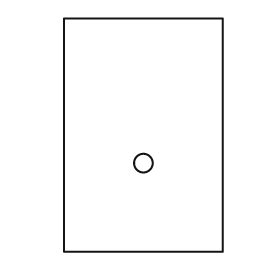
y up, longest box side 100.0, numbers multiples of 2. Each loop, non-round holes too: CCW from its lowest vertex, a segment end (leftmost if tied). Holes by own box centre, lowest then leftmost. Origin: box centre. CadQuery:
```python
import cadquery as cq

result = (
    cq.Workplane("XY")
    .moveTo(-34.0, -50.0)
    .lineTo(34.0, -50.0)
    .lineTo(34.0, 50.0)
    .lineTo(-34.0, 50.0)
    .close()
    .moveTo(0.0, -12.0)
    .circle(4.0)
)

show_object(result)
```